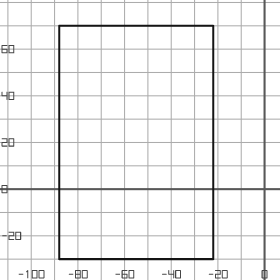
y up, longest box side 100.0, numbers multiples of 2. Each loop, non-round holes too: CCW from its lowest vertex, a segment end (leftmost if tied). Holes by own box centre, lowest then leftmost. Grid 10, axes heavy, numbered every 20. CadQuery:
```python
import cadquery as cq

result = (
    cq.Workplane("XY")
    .moveTo(-88.0, -30.0)
    .lineTo(-22.0, -30.0)
    .lineTo(-22.0, 70.0)
    .lineTo(-88.0, 70.0)
    .close()
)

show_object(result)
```